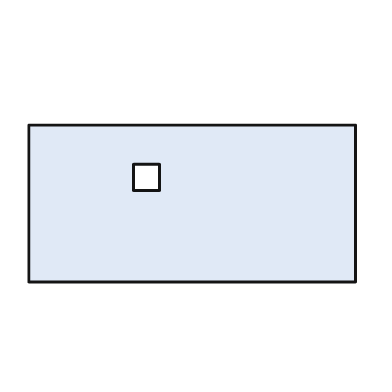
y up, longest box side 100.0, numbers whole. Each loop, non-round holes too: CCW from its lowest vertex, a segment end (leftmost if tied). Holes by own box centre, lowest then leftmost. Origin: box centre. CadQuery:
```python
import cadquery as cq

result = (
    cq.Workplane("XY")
    .moveTo(-50.0, -24.0)
    .lineTo(50.0, -24.0)
    .lineTo(50.0, 24.0)
    .lineTo(-50.0, 24.0)
    .close()
    .moveTo(-18.0, 4.0)
    .lineTo(-10.0, 4.0)
    .lineTo(-10.0, 12.0)
    .lineTo(-18.0, 12.0)
    .close()
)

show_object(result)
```